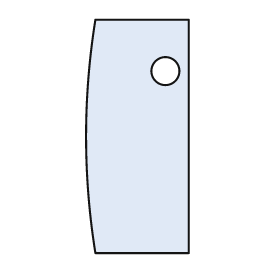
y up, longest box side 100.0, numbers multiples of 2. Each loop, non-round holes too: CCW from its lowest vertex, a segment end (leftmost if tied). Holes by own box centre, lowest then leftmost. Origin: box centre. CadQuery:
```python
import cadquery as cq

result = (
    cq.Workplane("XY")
    .moveTo(-18.0, -50.0)
    .lineTo(22.0, -50.0)
    .lineTo(22.0, 50.0)
    .lineTo(-18.0, 50.0)
    .threePointArc((-22.0, 0.0), (-18.0, -50.0))
    .close()
    .moveTo(12.0, 28.0)
    .circle(6.0)
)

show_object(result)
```